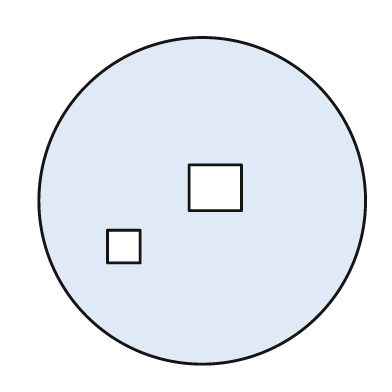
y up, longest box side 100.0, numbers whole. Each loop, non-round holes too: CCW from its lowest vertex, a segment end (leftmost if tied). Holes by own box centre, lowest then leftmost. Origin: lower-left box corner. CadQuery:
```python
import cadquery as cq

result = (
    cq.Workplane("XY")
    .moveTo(50.0, 50.0)
    .circle(50.0)
    .moveTo(21.0, 31.0)
    .lineTo(31.0, 31.0)
    .lineTo(31.0, 41.0)
    .lineTo(21.0, 41.0)
    .close()
    .moveTo(46.0, 47.0)
    .lineTo(62.0, 47.0)
    .lineTo(62.0, 61.0)
    .lineTo(46.0, 61.0)
    .close()
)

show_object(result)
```